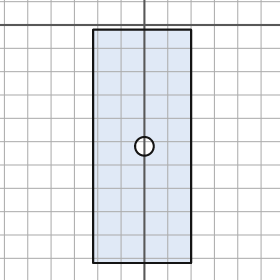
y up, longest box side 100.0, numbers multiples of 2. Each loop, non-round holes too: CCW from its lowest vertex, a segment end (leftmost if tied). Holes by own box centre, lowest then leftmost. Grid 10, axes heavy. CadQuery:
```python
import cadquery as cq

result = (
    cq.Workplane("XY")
    .moveTo(-22.0, -102.0)
    .lineTo(20.0, -102.0)
    .lineTo(20.0, -2.0)
    .lineTo(-22.0, -2.0)
    .close()
    .moveTo(0.0, -52.0)
    .circle(4.0)
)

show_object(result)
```